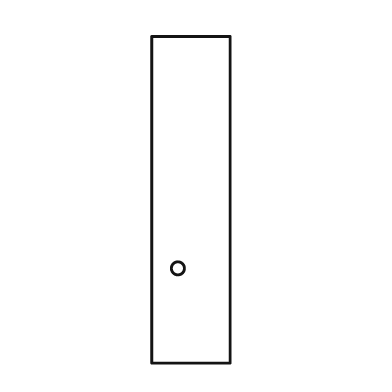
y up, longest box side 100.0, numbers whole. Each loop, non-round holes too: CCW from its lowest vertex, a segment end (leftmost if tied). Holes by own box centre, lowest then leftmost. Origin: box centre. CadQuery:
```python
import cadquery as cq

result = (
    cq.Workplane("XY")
    .moveTo(-12.0, -50.0)
    .lineTo(12.0, -50.0)
    .lineTo(12.0, 50.0)
    .lineTo(-12.0, 50.0)
    .close()
    .moveTo(-4.0, -21.0)
    .circle(2.0)
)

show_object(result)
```